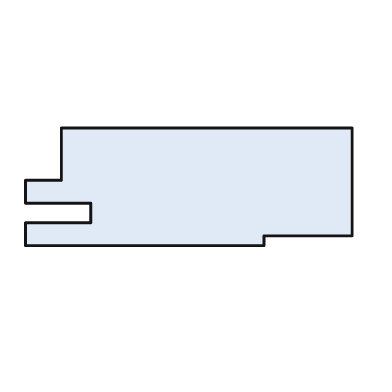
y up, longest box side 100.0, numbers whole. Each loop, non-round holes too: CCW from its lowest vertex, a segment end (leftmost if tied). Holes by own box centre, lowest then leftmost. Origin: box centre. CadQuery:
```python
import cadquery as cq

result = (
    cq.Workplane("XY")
    .moveTo(-50.0, -18.0)
    .lineTo(23.0, -18.0)
    .lineTo(23.0, -15.0)
    .lineTo(50.0, -15.0)
    .lineTo(50.0, 18.0)
    .lineTo(-39.0, 18.0)
    .lineTo(-39.0, 2.0)
    .lineTo(-50.0, 2.0)
    .lineTo(-50.0, -5.0)
    .lineTo(-30.0, -5.0)
    .lineTo(-30.0, -11.0)
    .lineTo(-50.0, -11.0)
    .close()
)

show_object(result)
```